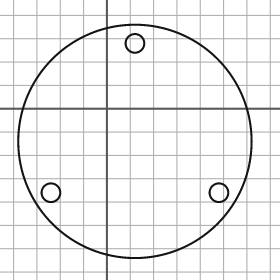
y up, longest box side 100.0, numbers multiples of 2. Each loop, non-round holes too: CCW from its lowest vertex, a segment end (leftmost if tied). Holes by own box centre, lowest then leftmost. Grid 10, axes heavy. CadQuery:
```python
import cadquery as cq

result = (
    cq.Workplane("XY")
    .moveTo(12.0, -14.0)
    .circle(50.0)
    .moveTo(-24.0, -36.0)
    .circle(4.0)
    .moveTo(48.0, -36.0)
    .circle(4.0)
    .moveTo(12.0, 28.0)
    .circle(4.0)
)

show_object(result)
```